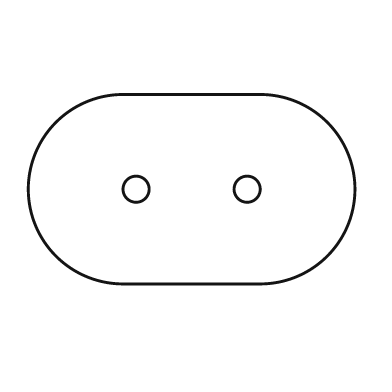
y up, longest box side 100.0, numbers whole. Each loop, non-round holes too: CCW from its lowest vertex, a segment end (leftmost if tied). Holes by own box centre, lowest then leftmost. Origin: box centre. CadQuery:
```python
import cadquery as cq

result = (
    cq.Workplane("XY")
    .moveTo(-21.0, -29.0)
    .lineTo(21.0, -29.0)
    .threePointArc((50.0, 0.0), (21.0, 29.0))
    .lineTo(-21.0, 29.0)
    .threePointArc((-50.0, 0.0), (-21.0, -29.0))
    .close()
    .moveTo(-17.0, 0.0)
    .circle(4.0)
    .moveTo(17.0, 0.0)
    .circle(4.0)
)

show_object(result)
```